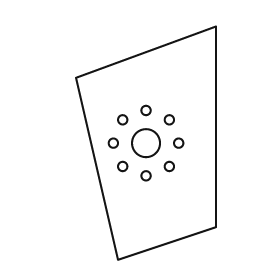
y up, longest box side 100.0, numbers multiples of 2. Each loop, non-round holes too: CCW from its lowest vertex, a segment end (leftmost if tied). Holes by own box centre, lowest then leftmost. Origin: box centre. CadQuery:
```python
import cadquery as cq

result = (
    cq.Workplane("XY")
    .moveTo(-12.0, -50.0)
    .lineTo(30.0, -36.0)
    .lineTo(30.0, 50.0)
    .lineTo(-30.0, 28.0)
    .close()
    .moveTo(0.0, -14.0)
    .circle(2.0)
    .moveTo(-10.0, -10.0)
    .circle(2.0)
    .moveTo(10.0, -10.0)
    .circle(2.0)
    .moveTo(-14.0, 0.0)
    .circle(2.0)
    .moveTo(0.0, 0.0)
    .circle(6.0)
    .moveTo(14.0, 0.0)
    .circle(2.0)
    .moveTo(-10.0, 10.0)
    .circle(2.0)
    .moveTo(10.0, 10.0)
    .circle(2.0)
    .moveTo(0.0, 14.0)
    .circle(2.0)
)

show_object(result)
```